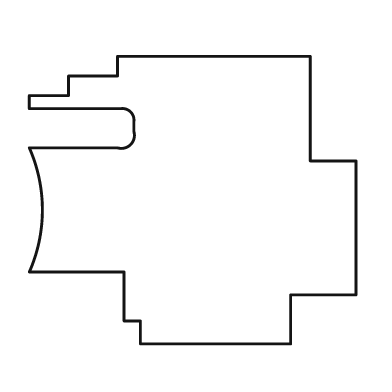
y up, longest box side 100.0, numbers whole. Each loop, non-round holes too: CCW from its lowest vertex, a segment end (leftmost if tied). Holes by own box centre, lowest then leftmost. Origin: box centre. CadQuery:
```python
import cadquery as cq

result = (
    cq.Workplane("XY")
    .moveTo(-16.0, -44.0)
    .lineTo(30.0, -44.0)
    .lineTo(30.0, -29.0)
    .lineTo(50.0, -29.0)
    .lineTo(50.0, 12.0)
    .lineTo(36.0, 12.0)
    .lineTo(36.0, 44.0)
    .lineTo(-23.0, 44.0)
    .lineTo(-23.0, 38.0)
    .lineTo(-38.0, 38.0)
    .lineTo(-38.0, 32.0)
    .lineTo(-50.0, 32.0)
    .lineTo(-50.0, 28.0)
    .lineTo(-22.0, 28.0)
    .threePointArc((-19.0, 27.0), (-18.0, 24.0))
    .lineTo(-18.0, 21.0)
    .threePointArc((-19.0, 17.0), (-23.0, 16.0))
    .lineTo(-50.0, 16.0)
    .threePointArc((-46.0, -3.0), (-50.0, -22.0))
    .lineTo(-21.0, -22.0)
    .lineTo(-21.0, -37.0)
    .lineTo(-16.0, -37.0)
    .close()
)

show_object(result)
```